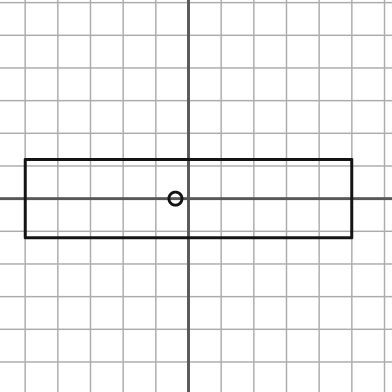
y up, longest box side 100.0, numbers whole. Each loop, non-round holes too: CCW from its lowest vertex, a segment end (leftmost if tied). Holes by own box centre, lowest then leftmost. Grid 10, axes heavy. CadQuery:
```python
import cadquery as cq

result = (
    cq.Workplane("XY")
    .moveTo(-50.0, -12.0)
    .lineTo(50.0, -12.0)
    .lineTo(50.0, 12.0)
    .lineTo(-50.0, 12.0)
    .close()
    .moveTo(-4.0, 0.0)
    .circle(2.0)
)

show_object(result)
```